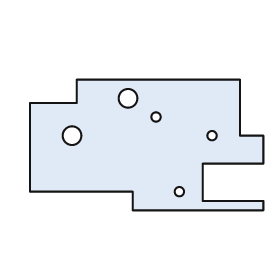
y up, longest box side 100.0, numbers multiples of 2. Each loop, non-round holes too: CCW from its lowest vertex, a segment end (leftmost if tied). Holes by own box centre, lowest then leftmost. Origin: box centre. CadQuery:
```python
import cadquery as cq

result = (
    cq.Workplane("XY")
    .moveTo(-6.0, -28.0)
    .lineTo(50.0, -28.0)
    .lineTo(50.0, -24.0)
    .lineTo(24.0, -24.0)
    .lineTo(24.0, -8.0)
    .lineTo(50.0, -8.0)
    .lineTo(50.0, 4.0)
    .lineTo(40.0, 4.0)
    .lineTo(40.0, 28.0)
    .lineTo(-30.0, 28.0)
    .lineTo(-30.0, 18.0)
    .lineTo(-50.0, 18.0)
    .lineTo(-50.0, -20.0)
    .lineTo(-6.0, -20.0)
    .close()
    .moveTo(14.0, -20.0)
    .circle(2.0)
    .moveTo(-32.0, 4.0)
    .circle(4.0)
    .moveTo(28.0, 4.0)
    .circle(2.0)
    .moveTo(4.0, 12.0)
    .circle(2.0)
    .moveTo(-8.0, 20.0)
    .circle(4.0)
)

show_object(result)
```